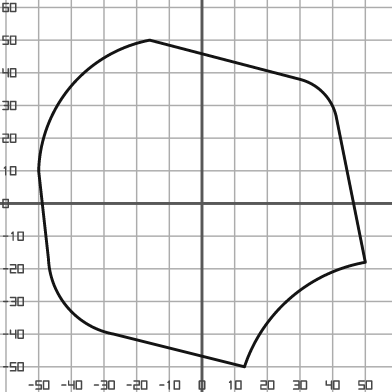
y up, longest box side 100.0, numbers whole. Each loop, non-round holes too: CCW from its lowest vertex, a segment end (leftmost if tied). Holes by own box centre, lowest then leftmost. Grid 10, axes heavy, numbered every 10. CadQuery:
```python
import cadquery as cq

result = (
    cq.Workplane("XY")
    .moveTo(13.0, -50.0)
    .threePointArc((27.0, -29.0), (50.0, -18.0))
    .lineTo(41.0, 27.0)
    .threePointArc((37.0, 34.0), (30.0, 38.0))
    .lineTo(-16.0, 50.0)
    .threePointArc((-40.0, 36.0), (-50.0, 10.0))
    .lineTo(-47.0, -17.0)
    .threePointArc((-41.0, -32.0), (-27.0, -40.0))
    .close()
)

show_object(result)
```